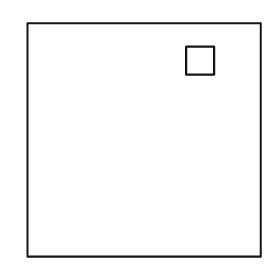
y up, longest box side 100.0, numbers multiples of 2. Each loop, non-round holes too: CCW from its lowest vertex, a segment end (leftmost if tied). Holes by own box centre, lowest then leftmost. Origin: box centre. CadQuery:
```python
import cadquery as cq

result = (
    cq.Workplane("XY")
    .moveTo(-50.0, -50.0)
    .lineTo(50.0, -50.0)
    .lineTo(50.0, 50.0)
    .lineTo(-50.0, 50.0)
    .close()
    .moveTo(18.0, 28.0)
    .lineTo(30.0, 28.0)
    .lineTo(30.0, 40.0)
    .lineTo(18.0, 40.0)
    .close()
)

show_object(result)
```